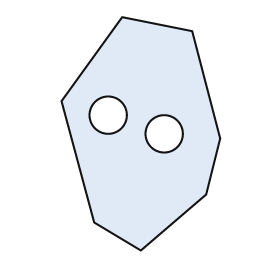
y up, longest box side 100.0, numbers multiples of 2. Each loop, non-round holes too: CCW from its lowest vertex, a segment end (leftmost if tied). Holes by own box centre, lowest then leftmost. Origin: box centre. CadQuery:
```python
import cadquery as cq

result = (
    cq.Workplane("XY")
    .moveTo(0.0, -50.0)
    .lineTo(28.0, -26.0)
    .lineTo(34.0, -2.0)
    .lineTo(22.0, 44.0)
    .lineTo(-8.0, 50.0)
    .lineTo(-34.0, 14.0)
    .lineTo(-20.0, -38.0)
    .close()
    .moveTo(10.0, 0.0)
    .circle(8.0)
    .moveTo(-14.0, 8.0)
    .circle(8.0)
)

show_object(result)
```